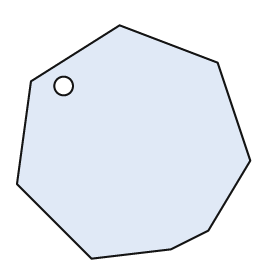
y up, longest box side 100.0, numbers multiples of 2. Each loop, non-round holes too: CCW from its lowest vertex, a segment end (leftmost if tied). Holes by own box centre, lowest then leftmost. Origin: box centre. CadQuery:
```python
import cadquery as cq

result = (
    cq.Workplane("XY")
    .moveTo(-18.0, -50.0)
    .lineTo(16.0, -46.0)
    .lineTo(32.0, -38.0)
    .lineTo(50.0, -8.0)
    .lineTo(36.0, 34.0)
    .lineTo(-6.0, 50.0)
    .lineTo(-44.0, 26.0)
    .lineTo(-50.0, -18.0)
    .close()
    .moveTo(-30.0, 24.0)
    .circle(4.0)
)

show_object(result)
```